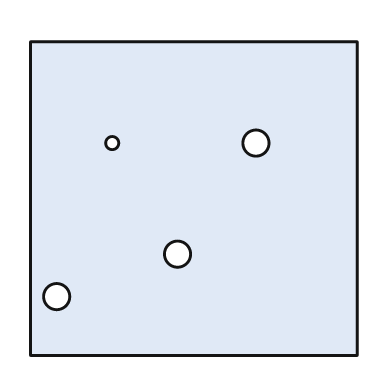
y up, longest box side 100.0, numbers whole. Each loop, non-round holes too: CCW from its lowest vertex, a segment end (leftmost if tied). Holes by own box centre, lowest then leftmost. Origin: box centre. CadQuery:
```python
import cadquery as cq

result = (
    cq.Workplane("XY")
    .moveTo(-50.0, -48.0)
    .lineTo(50.0, -48.0)
    .lineTo(50.0, 48.0)
    .lineTo(-50.0, 48.0)
    .close()
    .moveTo(-42.0, -30.0)
    .circle(4.0)
    .moveTo(-5.0, -17.0)
    .circle(4.0)
    .moveTo(-25.0, 17.0)
    .circle(2.0)
    .moveTo(19.0, 17.0)
    .circle(4.0)
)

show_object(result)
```